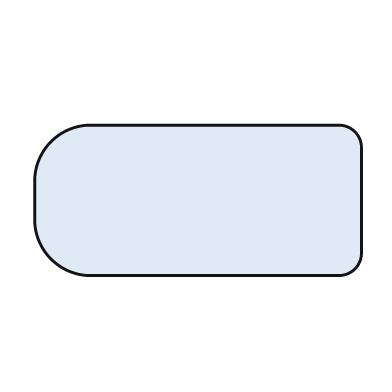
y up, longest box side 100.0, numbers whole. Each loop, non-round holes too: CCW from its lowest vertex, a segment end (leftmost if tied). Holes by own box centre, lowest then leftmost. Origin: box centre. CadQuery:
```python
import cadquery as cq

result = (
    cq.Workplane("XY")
    .moveTo(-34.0, -23.0)
    .lineTo(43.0, -23.0)
    .threePointArc((48.0, -21.0), (50.0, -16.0))
    .lineTo(50.0, 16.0)
    .threePointArc((48.0, 21.0), (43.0, 23.0))
    .lineTo(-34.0, 23.0)
    .threePointArc((-45.0, 18.0), (-50.0, 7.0))
    .lineTo(-50.0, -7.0)
    .threePointArc((-45.0, -18.0), (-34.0, -23.0))
    .close()
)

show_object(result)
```